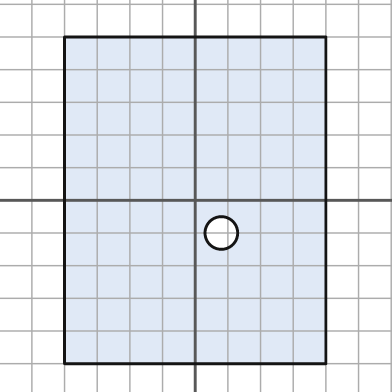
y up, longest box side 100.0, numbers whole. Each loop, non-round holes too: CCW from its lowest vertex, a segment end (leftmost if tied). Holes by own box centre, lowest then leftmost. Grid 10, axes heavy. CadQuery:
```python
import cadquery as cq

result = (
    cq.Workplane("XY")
    .moveTo(-40.0, -50.0)
    .lineTo(40.0, -50.0)
    .lineTo(40.0, 50.0)
    .lineTo(-40.0, 50.0)
    .close()
    .moveTo(8.0, -10.0)
    .circle(5.0)
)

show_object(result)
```